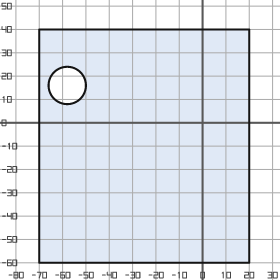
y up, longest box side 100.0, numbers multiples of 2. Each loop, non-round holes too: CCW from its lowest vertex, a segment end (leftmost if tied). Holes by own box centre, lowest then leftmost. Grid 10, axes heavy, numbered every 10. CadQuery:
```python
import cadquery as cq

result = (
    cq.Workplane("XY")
    .moveTo(-70.0, -60.0)
    .lineTo(20.0, -60.0)
    .lineTo(20.0, 40.0)
    .lineTo(-70.0, 40.0)
    .close()
    .moveTo(-58.0, 16.0)
    .circle(8.0)
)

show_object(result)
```